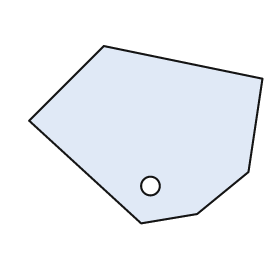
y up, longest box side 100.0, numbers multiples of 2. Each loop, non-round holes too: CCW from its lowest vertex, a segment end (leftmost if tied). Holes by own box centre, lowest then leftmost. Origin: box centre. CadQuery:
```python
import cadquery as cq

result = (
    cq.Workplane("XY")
    .moveTo(-2.0, -38.0)
    .lineTo(22.0, -34.0)
    .lineTo(44.0, -16.0)
    .lineTo(50.0, 24.0)
    .lineTo(-18.0, 38.0)
    .lineTo(-50.0, 6.0)
    .close()
    .moveTo(2.0, -22.0)
    .circle(4.0)
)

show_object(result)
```